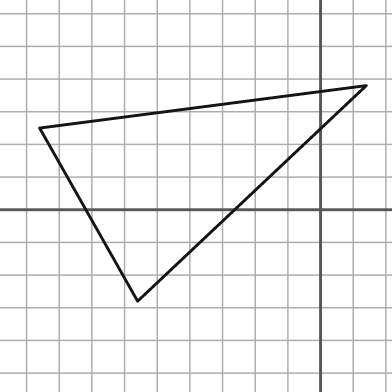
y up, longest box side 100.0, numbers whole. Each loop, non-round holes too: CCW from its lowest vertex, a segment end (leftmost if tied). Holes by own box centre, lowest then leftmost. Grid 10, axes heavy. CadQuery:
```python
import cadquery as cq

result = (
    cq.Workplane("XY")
    .moveTo(-56.0, -28.0)
    .lineTo(14.0, 38.0)
    .lineTo(-86.0, 25.0)
    .close()
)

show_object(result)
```